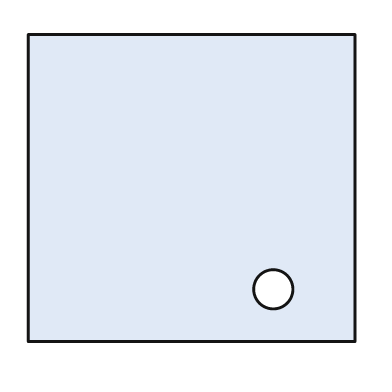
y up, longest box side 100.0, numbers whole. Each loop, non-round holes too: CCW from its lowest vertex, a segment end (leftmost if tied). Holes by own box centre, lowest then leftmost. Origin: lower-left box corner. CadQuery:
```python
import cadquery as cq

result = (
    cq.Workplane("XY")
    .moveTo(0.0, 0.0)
    .lineTo(100.0, 0.0)
    .lineTo(100.0, 94.0)
    .lineTo(0.0, 94.0)
    .close()
    .moveTo(75.0, 16.0)
    .circle(6.0)
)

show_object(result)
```